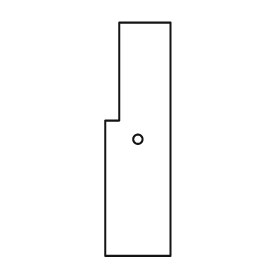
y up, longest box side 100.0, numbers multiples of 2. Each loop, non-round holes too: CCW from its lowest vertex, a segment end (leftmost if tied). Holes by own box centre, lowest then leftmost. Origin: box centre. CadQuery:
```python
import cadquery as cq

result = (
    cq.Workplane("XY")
    .moveTo(-14.0, -50.0)
    .lineTo(14.0, -50.0)
    .lineTo(14.0, 50.0)
    .lineTo(-8.0, 50.0)
    .lineTo(-8.0, 8.0)
    .lineTo(-14.0, 8.0)
    .close()
    .moveTo(0.0, 0.0)
    .circle(2.0)
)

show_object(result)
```